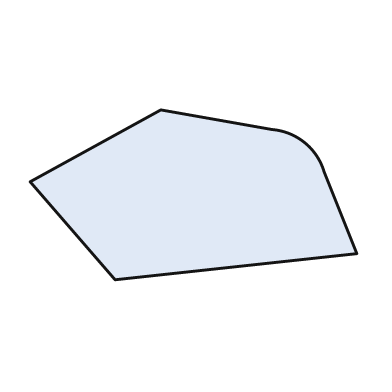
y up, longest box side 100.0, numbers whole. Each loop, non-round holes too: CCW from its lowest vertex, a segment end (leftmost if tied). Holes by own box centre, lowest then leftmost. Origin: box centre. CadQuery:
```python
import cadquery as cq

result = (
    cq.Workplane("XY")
    .moveTo(-24.0, -26.0)
    .lineTo(50.0, -18.0)
    .lineTo(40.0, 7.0)
    .threePointArc((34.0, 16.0), (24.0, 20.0))
    .lineTo(-10.0, 26.0)
    .lineTo(-50.0, 4.0)
    .close()
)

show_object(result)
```